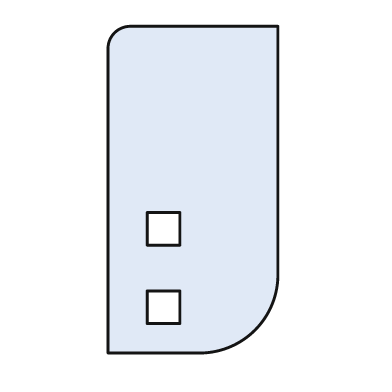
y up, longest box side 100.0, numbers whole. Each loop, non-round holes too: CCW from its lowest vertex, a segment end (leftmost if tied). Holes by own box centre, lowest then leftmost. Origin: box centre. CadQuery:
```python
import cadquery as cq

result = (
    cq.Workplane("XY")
    .moveTo(-26.0, -50.0)
    .lineTo(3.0, -50.0)
    .threePointArc((19.0, -43.0), (26.0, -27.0))
    .lineTo(26.0, 50.0)
    .lineTo(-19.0, 50.0)
    .threePointArc((-24.0, 48.0), (-26.0, 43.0))
    .close()
    .moveTo(-14.0, -41.0)
    .lineTo(-4.0, -41.0)
    .lineTo(-4.0, -31.0)
    .lineTo(-14.0, -31.0)
    .close()
    .moveTo(-14.0, -17.0)
    .lineTo(-4.0, -17.0)
    .lineTo(-4.0, -7.0)
    .lineTo(-14.0, -7.0)
    .close()
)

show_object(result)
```